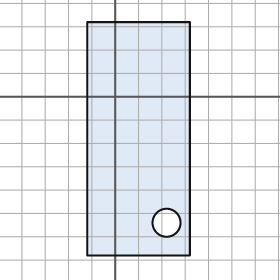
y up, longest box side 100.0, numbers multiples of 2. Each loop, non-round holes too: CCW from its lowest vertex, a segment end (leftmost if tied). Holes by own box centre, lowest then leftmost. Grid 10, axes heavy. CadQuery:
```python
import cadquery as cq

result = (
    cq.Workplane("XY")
    .moveTo(-12.0, -68.0)
    .lineTo(32.0, -68.0)
    .lineTo(32.0, 32.0)
    .lineTo(-12.0, 32.0)
    .close()
    .moveTo(22.0, -54.0)
    .circle(6.0)
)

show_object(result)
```